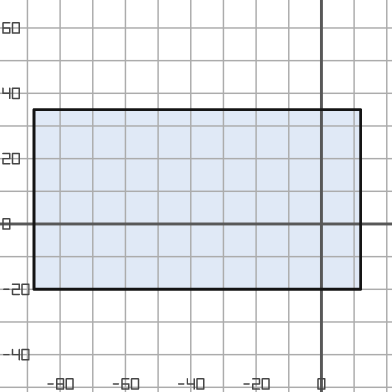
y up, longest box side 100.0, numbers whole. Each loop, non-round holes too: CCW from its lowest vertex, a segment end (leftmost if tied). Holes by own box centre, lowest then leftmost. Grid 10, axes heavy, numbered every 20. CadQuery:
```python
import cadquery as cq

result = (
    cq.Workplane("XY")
    .moveTo(-88.0, -20.0)
    .lineTo(12.0, -20.0)
    .lineTo(12.0, 35.0)
    .lineTo(-88.0, 35.0)
    .close()
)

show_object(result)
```